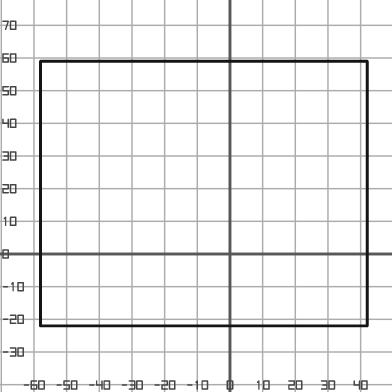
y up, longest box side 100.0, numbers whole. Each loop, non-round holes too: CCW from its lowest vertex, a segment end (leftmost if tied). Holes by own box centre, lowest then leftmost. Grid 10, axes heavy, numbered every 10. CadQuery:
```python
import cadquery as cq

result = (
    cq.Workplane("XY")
    .moveTo(-58.0, -22.0)
    .lineTo(42.0, -22.0)
    .lineTo(42.0, 59.0)
    .lineTo(-58.0, 59.0)
    .close()
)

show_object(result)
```